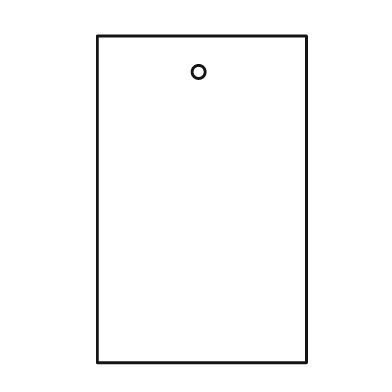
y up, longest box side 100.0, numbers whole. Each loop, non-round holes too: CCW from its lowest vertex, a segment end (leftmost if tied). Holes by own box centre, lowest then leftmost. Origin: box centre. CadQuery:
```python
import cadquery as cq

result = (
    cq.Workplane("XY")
    .moveTo(-32.0, -50.0)
    .lineTo(32.0, -50.0)
    .lineTo(32.0, 50.0)
    .lineTo(-32.0, 50.0)
    .close()
    .moveTo(-1.0, 39.0)
    .circle(2.0)
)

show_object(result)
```